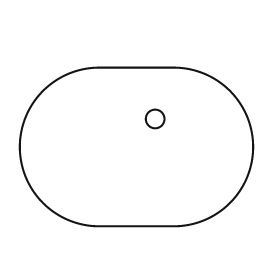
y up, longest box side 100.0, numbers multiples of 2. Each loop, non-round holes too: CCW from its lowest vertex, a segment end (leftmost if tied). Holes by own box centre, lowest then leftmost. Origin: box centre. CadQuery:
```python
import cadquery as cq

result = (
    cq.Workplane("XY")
    .moveTo(-16.0, -34.0)
    .lineTo(16.0, -34.0)
    .threePointArc((50.0, 0.0), (16.0, 34.0))
    .lineTo(-16.0, 34.0)
    .threePointArc((-50.0, 0.0), (-16.0, -34.0))
    .close()
    .moveTo(8.0, 12.0)
    .circle(4.0)
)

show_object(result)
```